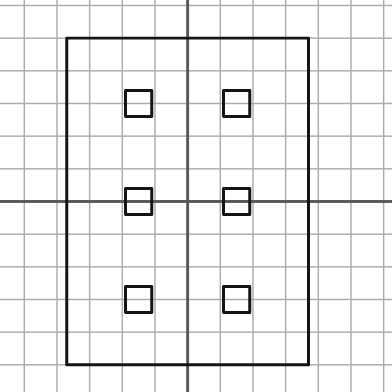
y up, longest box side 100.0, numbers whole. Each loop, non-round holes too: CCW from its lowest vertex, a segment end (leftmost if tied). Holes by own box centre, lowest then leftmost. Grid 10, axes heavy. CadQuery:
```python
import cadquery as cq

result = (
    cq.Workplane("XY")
    .moveTo(-37.0, -50.0)
    .lineTo(37.0, -50.0)
    .lineTo(37.0, 50.0)
    .lineTo(-37.0, 50.0)
    .close()
    .moveTo(-19.0, -34.0)
    .lineTo(-11.0, -34.0)
    .lineTo(-11.0, -26.0)
    .lineTo(-19.0, -26.0)
    .close()
    .moveTo(11.0, -34.0)
    .lineTo(19.0, -34.0)
    .lineTo(19.0, -26.0)
    .lineTo(11.0, -26.0)
    .close()
    .moveTo(-19.0, -4.0)
    .lineTo(-11.0, -4.0)
    .lineTo(-11.0, 4.0)
    .lineTo(-19.0, 4.0)
    .close()
    .moveTo(11.0, -4.0)
    .lineTo(19.0, -4.0)
    .lineTo(19.0, 4.0)
    .lineTo(11.0, 4.0)
    .close()
    .moveTo(-19.0, 26.0)
    .lineTo(-11.0, 26.0)
    .lineTo(-11.0, 34.0)
    .lineTo(-19.0, 34.0)
    .close()
    .moveTo(11.0, 26.0)
    .lineTo(19.0, 26.0)
    .lineTo(19.0, 34.0)
    .lineTo(11.0, 34.0)
    .close()
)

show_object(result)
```